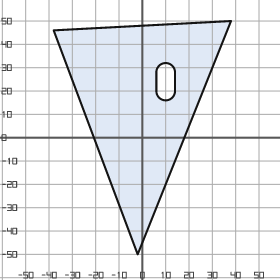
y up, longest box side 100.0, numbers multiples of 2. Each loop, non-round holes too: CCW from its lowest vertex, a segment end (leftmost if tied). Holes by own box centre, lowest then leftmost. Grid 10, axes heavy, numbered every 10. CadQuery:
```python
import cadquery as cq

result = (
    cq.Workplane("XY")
    .moveTo(-2.0, -50.0)
    .lineTo(38.0, 50.0)
    .lineTo(-38.0, 46.0)
    .close()
    .moveTo(6.0, 20.0)
    .threePointArc((10.0, 16.0), (14.0, 20.0))
    .lineTo(14.0, 28.0)
    .threePointArc((10.0, 32.0), (6.0, 28.0))
    .close()
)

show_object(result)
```